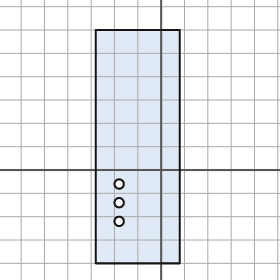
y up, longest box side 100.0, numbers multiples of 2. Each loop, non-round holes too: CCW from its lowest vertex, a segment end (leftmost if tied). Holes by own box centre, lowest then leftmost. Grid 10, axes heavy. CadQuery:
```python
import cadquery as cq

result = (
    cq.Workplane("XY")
    .moveTo(-28.0, -40.0)
    .lineTo(8.0, -40.0)
    .lineTo(8.0, 60.0)
    .lineTo(-28.0, 60.0)
    .close()
    .moveTo(-18.0, -22.0)
    .circle(2.0)
    .moveTo(-18.0, -14.0)
    .circle(2.0)
    .moveTo(-18.0, -6.0)
    .circle(2.0)
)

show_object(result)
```